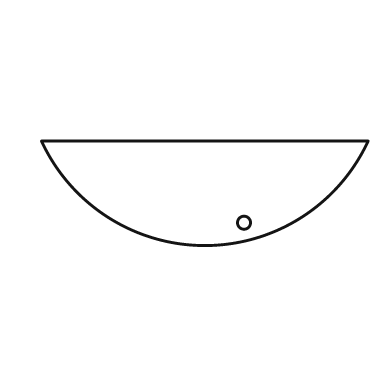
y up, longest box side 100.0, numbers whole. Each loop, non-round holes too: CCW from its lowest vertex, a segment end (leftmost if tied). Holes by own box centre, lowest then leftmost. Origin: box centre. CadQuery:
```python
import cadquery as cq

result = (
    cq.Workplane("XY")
    .moveTo(-50.0, 16.0)
    .threePointArc((0.0, -16.0), (50.0, 16.0))
    .close()
    .moveTo(12.0, -9.0)
    .circle(2.0)
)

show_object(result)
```